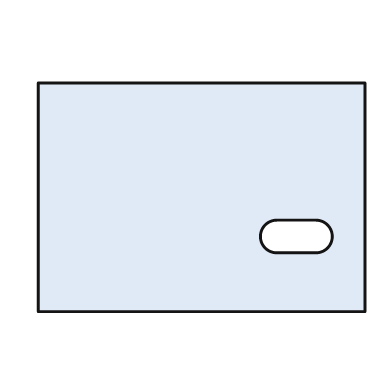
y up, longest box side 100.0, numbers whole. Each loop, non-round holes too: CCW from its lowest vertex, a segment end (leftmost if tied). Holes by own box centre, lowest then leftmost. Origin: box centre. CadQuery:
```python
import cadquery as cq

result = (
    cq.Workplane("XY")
    .moveTo(-50.0, -35.0)
    .lineTo(50.0, -35.0)
    .lineTo(50.0, 35.0)
    .lineTo(-50.0, 35.0)
    .close()
    .moveTo(23.0, -17.0)
    .lineTo(35.0, -17.0)
    .threePointArc((40.0, -12.0), (35.0, -7.0))
    .lineTo(23.0, -7.0)
    .threePointArc((18.0, -12.0), (23.0, -17.0))
    .close()
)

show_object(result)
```